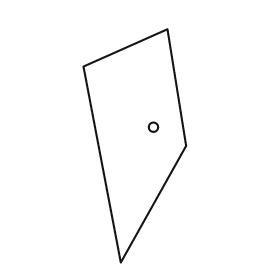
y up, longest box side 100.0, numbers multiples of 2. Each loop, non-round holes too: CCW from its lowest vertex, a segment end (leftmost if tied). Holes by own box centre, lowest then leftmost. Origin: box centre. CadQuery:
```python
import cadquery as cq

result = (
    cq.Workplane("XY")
    .moveTo(-6.0, -50.0)
    .lineTo(22.0, 0.0)
    .lineTo(14.0, 50.0)
    .lineTo(-22.0, 34.0)
    .close()
    .moveTo(8.0, 8.0)
    .circle(2.0)
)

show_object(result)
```